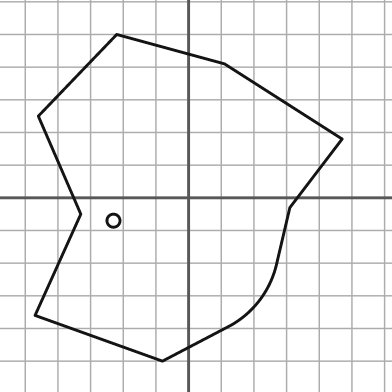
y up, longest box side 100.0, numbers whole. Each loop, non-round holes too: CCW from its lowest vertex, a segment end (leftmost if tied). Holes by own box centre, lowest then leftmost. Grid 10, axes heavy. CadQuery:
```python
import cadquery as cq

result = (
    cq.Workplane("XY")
    .moveTo(-8.0, -50.0)
    .lineTo(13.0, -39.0)
    .threePointArc((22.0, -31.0), (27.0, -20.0))
    .lineTo(31.0, -3.0)
    .lineTo(47.0, 18.0)
    .lineTo(11.0, 41.0)
    .lineTo(-22.0, 50.0)
    .lineTo(-46.0, 25.0)
    .lineTo(-33.0, -5.0)
    .lineTo(-47.0, -36.0)
    .close()
    .moveTo(-23.0, -7.0)
    .circle(2.0)
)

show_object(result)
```